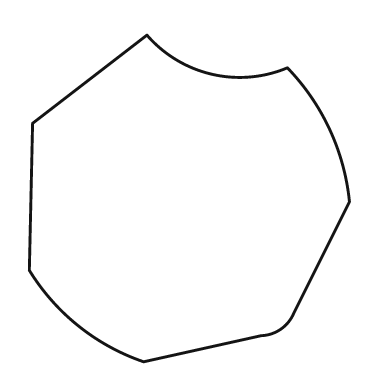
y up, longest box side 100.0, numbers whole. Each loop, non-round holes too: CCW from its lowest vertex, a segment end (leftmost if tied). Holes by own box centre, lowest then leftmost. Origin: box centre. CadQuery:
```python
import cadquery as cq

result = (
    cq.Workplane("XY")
    .moveTo(-14.0, -50.0)
    .lineTo(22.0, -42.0)
    .threePointArc((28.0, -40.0), (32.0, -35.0))
    .lineTo(49.0, -1.0)
    .threePointArc((43.0, 21.0), (30.0, 40.0))
    .threePointArc((7.0, 38.0), (-13.0, 50.0))
    .lineTo(-48.0, 23.0)
    .lineTo(-49.0, -22.0)
    .threePointArc((-34.0, -39.0), (-14.0, -50.0))
    .close()
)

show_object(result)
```